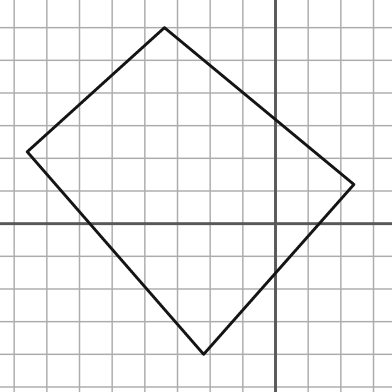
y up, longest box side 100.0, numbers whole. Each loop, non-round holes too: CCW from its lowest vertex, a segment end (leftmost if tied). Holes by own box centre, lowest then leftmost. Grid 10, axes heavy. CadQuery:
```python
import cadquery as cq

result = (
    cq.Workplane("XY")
    .moveTo(-22.0, -40.0)
    .lineTo(24.0, 12.0)
    .lineTo(-34.0, 60.0)
    .lineTo(-76.0, 22.0)
    .close()
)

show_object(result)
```